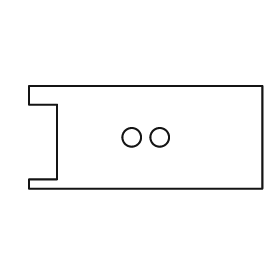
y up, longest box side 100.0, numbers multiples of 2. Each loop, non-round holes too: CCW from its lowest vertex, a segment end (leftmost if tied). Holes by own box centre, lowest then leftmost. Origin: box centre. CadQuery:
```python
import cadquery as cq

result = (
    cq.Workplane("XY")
    .moveTo(-50.0, -22.0)
    .lineTo(50.0, -22.0)
    .lineTo(50.0, 22.0)
    .lineTo(-50.0, 22.0)
    .lineTo(-50.0, 14.0)
    .lineTo(-38.0, 14.0)
    .lineTo(-38.0, -18.0)
    .lineTo(-50.0, -18.0)
    .close()
    .moveTo(-6.0, 0.0)
    .circle(4.0)
    .moveTo(6.0, 0.0)
    .circle(4.0)
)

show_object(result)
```